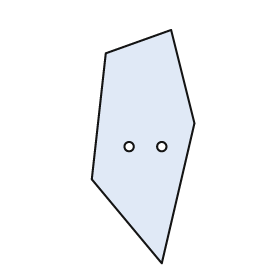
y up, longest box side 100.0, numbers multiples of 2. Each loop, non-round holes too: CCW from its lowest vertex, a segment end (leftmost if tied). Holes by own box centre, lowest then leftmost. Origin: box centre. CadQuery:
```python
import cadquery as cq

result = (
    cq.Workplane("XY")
    .moveTo(8.0, -50.0)
    .lineTo(22.0, 10.0)
    .lineTo(12.0, 50.0)
    .lineTo(-16.0, 40.0)
    .lineTo(-22.0, -14.0)
    .close()
    .moveTo(-6.0, 0.0)
    .circle(2.0)
    .moveTo(8.0, 0.0)
    .circle(2.0)
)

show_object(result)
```